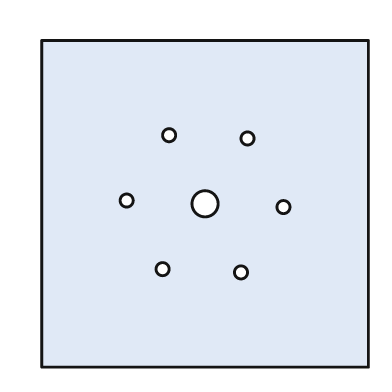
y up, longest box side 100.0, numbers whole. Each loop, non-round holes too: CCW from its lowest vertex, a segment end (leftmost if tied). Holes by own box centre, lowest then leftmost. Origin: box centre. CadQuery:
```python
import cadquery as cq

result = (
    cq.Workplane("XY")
    .moveTo(-50.0, -50.0)
    .lineTo(50.0, -50.0)
    .lineTo(50.0, 50.0)
    .lineTo(-50.0, 50.0)
    .close()
    .moveTo(11.0, -21.0)
    .circle(2.0)
    .moveTo(-13.0, -20.0)
    .circle(2.0)
    .moveTo(24.0, -1.0)
    .circle(2.0)
    .moveTo(0.0, 0.0)
    .circle(4.0)
    .moveTo(-24.0, 1.0)
    .circle(2.0)
    .moveTo(13.0, 20.0)
    .circle(2.0)
    .moveTo(-11.0, 21.0)
    .circle(2.0)
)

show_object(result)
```